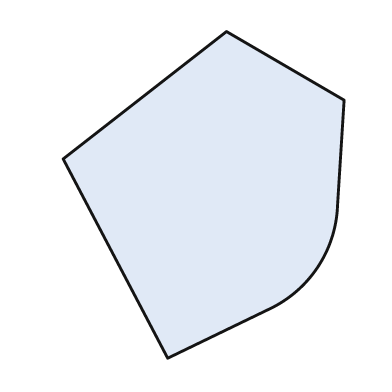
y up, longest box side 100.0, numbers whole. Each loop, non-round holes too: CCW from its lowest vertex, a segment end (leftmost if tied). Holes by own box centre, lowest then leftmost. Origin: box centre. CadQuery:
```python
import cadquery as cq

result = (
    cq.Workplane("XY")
    .moveTo(-11.0, -50.0)
    .lineTo(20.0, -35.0)
    .threePointArc((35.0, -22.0), (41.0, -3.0))
    .lineTo(43.0, 29.0)
    .lineTo(7.0, 50.0)
    .lineTo(-43.0, 11.0)
    .close()
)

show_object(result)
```